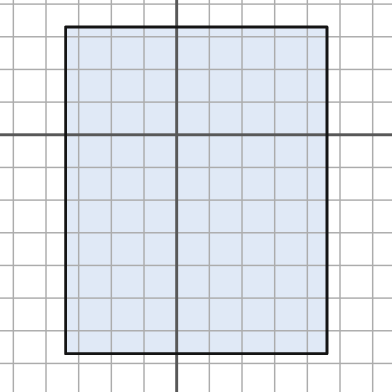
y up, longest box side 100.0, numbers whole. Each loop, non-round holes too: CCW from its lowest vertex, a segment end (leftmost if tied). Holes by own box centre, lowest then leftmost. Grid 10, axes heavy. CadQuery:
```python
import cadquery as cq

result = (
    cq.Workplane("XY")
    .moveTo(-34.0, -67.0)
    .lineTo(46.0, -67.0)
    .lineTo(46.0, 33.0)
    .lineTo(-34.0, 33.0)
    .close()
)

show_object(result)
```